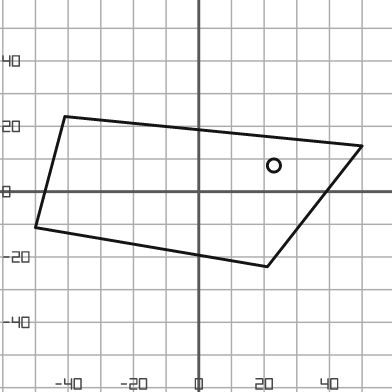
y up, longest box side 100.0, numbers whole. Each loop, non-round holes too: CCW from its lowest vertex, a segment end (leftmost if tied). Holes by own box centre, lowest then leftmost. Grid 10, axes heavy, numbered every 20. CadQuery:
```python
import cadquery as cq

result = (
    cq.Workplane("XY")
    .moveTo(21.0, -23.0)
    .lineTo(50.0, 14.0)
    .lineTo(-41.0, 23.0)
    .lineTo(-50.0, -11.0)
    .close()
    .moveTo(23.0, 8.0)
    .circle(2.0)
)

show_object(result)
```